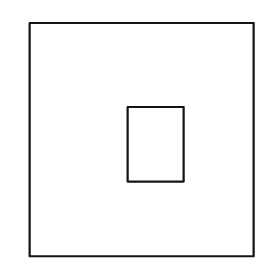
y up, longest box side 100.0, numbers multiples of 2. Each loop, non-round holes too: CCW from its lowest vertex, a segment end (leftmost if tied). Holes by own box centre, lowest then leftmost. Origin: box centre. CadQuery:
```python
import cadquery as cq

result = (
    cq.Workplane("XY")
    .moveTo(-48.0, -50.0)
    .lineTo(48.0, -50.0)
    .lineTo(48.0, 50.0)
    .lineTo(-48.0, 50.0)
    .close()
    .moveTo(-6.0, -18.0)
    .lineTo(18.0, -18.0)
    .lineTo(18.0, 14.0)
    .lineTo(-6.0, 14.0)
    .close()
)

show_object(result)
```